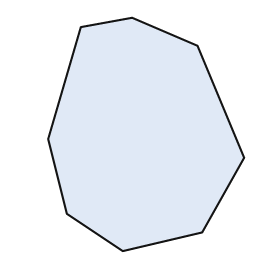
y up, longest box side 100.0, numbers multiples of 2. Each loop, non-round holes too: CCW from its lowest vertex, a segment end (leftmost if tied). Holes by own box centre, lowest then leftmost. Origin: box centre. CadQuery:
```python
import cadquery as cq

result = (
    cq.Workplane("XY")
    .moveTo(-10.0, -50.0)
    .lineTo(24.0, -42.0)
    .lineTo(42.0, -10.0)
    .lineTo(22.0, 38.0)
    .lineTo(-6.0, 50.0)
    .lineTo(-28.0, 46.0)
    .lineTo(-42.0, -2.0)
    .lineTo(-34.0, -34.0)
    .close()
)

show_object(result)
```